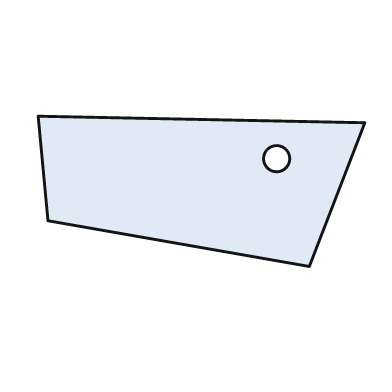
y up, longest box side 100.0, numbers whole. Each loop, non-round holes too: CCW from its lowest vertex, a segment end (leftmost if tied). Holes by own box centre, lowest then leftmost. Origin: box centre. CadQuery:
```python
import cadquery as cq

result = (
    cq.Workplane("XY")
    .moveTo(33.0, -23.0)
    .lineTo(50.0, 21.0)
    .lineTo(-50.0, 23.0)
    .lineTo(-47.0, -9.0)
    .close()
    .moveTo(23.0, 10.0)
    .circle(4.0)
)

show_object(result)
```